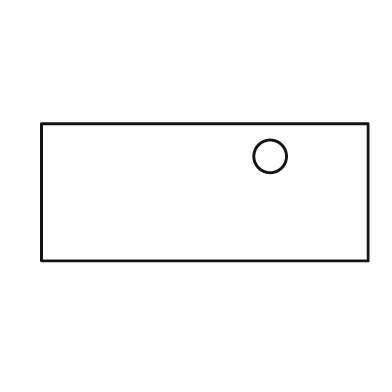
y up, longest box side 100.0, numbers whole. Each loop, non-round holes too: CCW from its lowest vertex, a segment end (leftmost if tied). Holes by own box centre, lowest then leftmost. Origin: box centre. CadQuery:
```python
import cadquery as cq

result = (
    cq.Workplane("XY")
    .moveTo(-50.0, -21.0)
    .lineTo(50.0, -21.0)
    .lineTo(50.0, 21.0)
    .lineTo(-50.0, 21.0)
    .close()
    .moveTo(20.0, 11.0)
    .circle(5.0)
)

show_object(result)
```